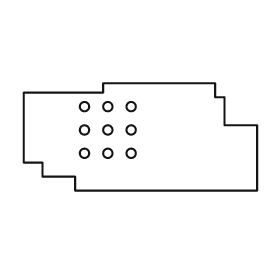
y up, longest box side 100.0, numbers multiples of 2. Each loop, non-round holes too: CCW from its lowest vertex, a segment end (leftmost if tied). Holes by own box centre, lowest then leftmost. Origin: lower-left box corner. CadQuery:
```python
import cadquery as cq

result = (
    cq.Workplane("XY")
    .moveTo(22.0, 0.0)
    .lineTo(100.0, 0.0)
    .lineTo(100.0, 28.0)
    .lineTo(86.0, 28.0)
    .lineTo(86.0, 40.0)
    .lineTo(82.0, 40.0)
    .lineTo(82.0, 46.0)
    .lineTo(34.0, 46.0)
    .lineTo(34.0, 42.0)
    .lineTo(0.0, 42.0)
    .lineTo(0.0, 12.0)
    .lineTo(8.0, 12.0)
    .lineTo(8.0, 6.0)
    .lineTo(22.0, 6.0)
    .close()
    .moveTo(26.0, 16.0)
    .circle(2.0)
    .moveTo(36.0, 16.0)
    .circle(2.0)
    .moveTo(46.0, 16.0)
    .circle(2.0)
    .moveTo(26.0, 26.0)
    .circle(2.0)
    .moveTo(36.0, 26.0)
    .circle(2.0)
    .moveTo(46.0, 26.0)
    .circle(2.0)
    .moveTo(26.0, 36.0)
    .circle(2.0)
    .moveTo(36.0, 36.0)
    .circle(2.0)
    .moveTo(46.0, 36.0)
    .circle(2.0)
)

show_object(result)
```